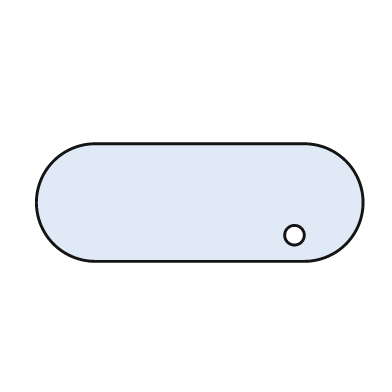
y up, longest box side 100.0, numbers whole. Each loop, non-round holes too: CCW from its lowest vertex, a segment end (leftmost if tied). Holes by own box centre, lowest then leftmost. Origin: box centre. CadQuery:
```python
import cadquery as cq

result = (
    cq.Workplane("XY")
    .moveTo(-32.0, -18.0)
    .lineTo(32.0, -18.0)
    .threePointArc((50.0, 0.0), (32.0, 18.0))
    .lineTo(-32.0, 18.0)
    .threePointArc((-50.0, 0.0), (-32.0, -18.0))
    .close()
    .moveTo(29.0, -10.0)
    .circle(3.0)
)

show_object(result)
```